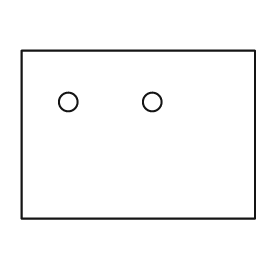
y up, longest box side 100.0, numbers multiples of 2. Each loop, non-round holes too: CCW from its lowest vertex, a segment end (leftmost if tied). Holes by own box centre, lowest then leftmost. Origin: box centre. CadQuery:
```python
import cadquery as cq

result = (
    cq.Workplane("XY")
    .moveTo(-50.0, -36.0)
    .lineTo(50.0, -36.0)
    .lineTo(50.0, 36.0)
    .lineTo(-50.0, 36.0)
    .close()
    .moveTo(-30.0, 14.0)
    .circle(4.0)
    .moveTo(6.0, 14.0)
    .circle(4.0)
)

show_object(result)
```